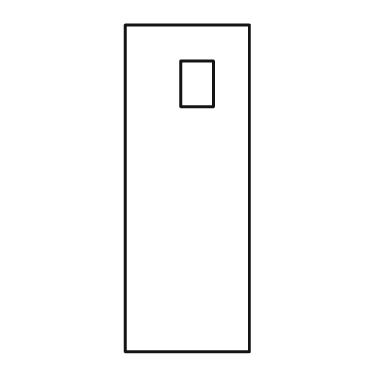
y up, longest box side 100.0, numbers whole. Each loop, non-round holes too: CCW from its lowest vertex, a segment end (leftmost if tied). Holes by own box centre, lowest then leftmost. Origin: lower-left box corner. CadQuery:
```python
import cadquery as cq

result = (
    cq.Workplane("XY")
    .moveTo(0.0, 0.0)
    .lineTo(38.0, 0.0)
    .lineTo(38.0, 100.0)
    .lineTo(0.0, 100.0)
    .close()
    .moveTo(17.0, 75.0)
    .lineTo(27.0, 75.0)
    .lineTo(27.0, 89.0)
    .lineTo(17.0, 89.0)
    .close()
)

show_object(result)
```